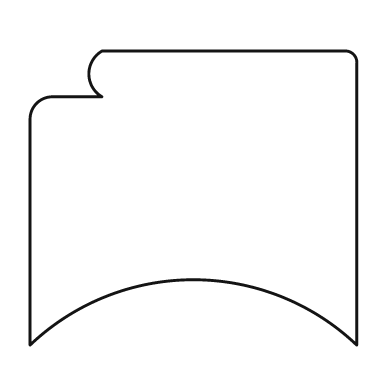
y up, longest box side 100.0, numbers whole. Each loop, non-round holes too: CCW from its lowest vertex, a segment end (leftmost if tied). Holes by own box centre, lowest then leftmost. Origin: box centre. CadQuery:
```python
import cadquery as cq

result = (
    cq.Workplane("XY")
    .moveTo(-50.0, -45.0)
    .threePointArc((0.0, -25.0), (50.0, -45.0))
    .lineTo(50.0, 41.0)
    .threePointArc((49.0, 44.0), (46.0, 45.0))
    .lineTo(-28.0, 45.0)
    .threePointArc((-32.0, 38.0), (-28.0, 31.0))
    .lineTo(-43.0, 31.0)
    .threePointArc((-48.0, 29.0), (-50.0, 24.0))
    .close()
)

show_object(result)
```